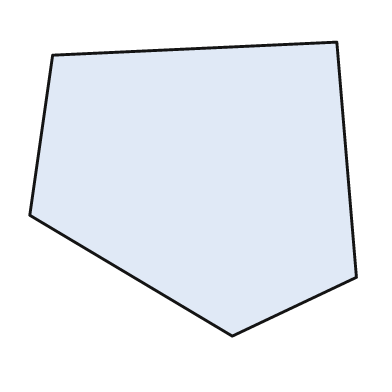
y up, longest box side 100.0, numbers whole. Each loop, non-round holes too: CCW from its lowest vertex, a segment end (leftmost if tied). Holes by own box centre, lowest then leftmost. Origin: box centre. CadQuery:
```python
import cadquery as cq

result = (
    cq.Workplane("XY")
    .moveTo(12.0, -45.0)
    .lineTo(50.0, -27.0)
    .lineTo(44.0, 45.0)
    .lineTo(-43.0, 41.0)
    .lineTo(-50.0, -8.0)
    .close()
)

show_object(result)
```